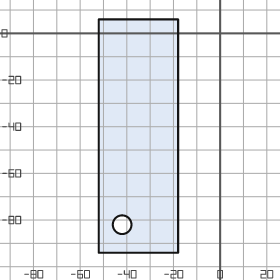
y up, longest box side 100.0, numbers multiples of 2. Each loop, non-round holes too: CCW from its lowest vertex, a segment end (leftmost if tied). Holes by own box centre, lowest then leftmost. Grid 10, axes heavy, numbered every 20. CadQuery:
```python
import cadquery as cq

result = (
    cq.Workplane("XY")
    .moveTo(-52.0, -94.0)
    .lineTo(-18.0, -94.0)
    .lineTo(-18.0, 6.0)
    .lineTo(-52.0, 6.0)
    .close()
    .moveTo(-42.0, -82.0)
    .circle(4.0)
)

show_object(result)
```